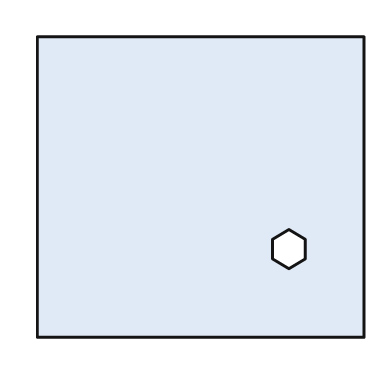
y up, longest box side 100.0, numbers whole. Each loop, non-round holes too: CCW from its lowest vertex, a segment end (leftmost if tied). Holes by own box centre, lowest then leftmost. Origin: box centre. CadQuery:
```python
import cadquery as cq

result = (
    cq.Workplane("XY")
    .moveTo(-50.0, -46.0)
    .lineTo(50.0, -46.0)
    .lineTo(50.0, 46.0)
    .lineTo(-50.0, 46.0)
    .close()
    .moveTo(27.0, -25.0)
    .lineTo(32.0, -22.0)
    .lineTo(32.0, -16.0)
    .lineTo(27.0, -13.0)
    .lineTo(22.0, -16.0)
    .lineTo(22.0, -22.0)
    .close()
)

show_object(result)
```